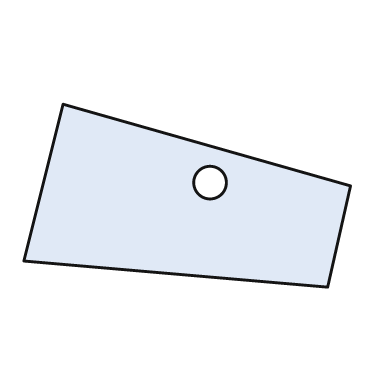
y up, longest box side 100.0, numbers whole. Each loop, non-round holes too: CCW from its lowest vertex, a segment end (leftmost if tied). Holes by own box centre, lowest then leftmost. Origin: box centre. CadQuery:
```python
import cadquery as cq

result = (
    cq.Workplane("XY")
    .moveTo(43.0, -28.0)
    .lineTo(50.0, 3.0)
    .lineTo(-38.0, 28.0)
    .lineTo(-50.0, -20.0)
    .close()
    .moveTo(7.0, 4.0)
    .circle(5.0)
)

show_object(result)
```